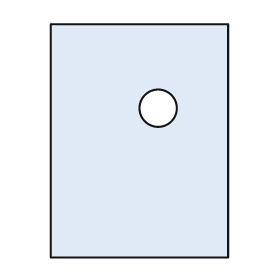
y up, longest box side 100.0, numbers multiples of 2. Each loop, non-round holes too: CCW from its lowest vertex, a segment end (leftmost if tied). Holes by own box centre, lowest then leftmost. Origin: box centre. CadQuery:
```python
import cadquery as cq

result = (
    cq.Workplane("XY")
    .moveTo(-38.0, -50.0)
    .lineTo(38.0, -50.0)
    .lineTo(38.0, 50.0)
    .lineTo(-38.0, 50.0)
    .close()
    .moveTo(8.0, 14.0)
    .circle(8.0)
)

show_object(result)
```